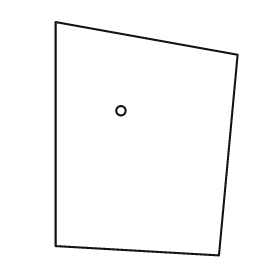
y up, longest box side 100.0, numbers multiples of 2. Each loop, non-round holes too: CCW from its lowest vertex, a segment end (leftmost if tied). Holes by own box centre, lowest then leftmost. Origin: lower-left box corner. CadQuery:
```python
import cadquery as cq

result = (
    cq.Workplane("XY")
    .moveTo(70.0, 0.0)
    .lineTo(78.0, 86.0)
    .lineTo(0.0, 100.0)
    .lineTo(0.0, 4.0)
    .close()
    .moveTo(28.0, 62.0)
    .circle(2.0)
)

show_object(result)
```